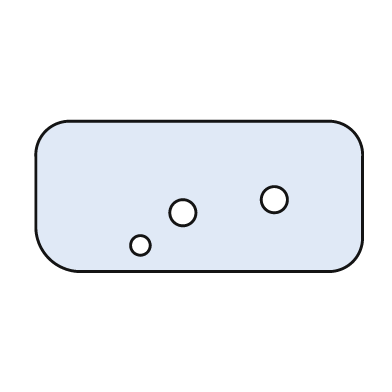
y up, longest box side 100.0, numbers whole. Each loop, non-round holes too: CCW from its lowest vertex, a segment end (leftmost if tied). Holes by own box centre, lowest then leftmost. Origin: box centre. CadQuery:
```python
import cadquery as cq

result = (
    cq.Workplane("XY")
    .moveTo(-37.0, -23.0)
    .lineTo(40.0, -23.0)
    .threePointArc((47.0, -20.0), (50.0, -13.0))
    .lineTo(50.0, 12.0)
    .threePointArc((47.0, 20.0), (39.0, 23.0))
    .lineTo(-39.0, 23.0)
    .threePointArc((-47.0, 20.0), (-50.0, 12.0))
    .lineTo(-50.0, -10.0)
    .threePointArc((-46.0, -19.0), (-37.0, -23.0))
    .close()
    .moveTo(-18.0, -15.0)
    .circle(3.0)
    .moveTo(-5.0, -5.0)
    .circle(4.0)
    .moveTo(23.0, -1.0)
    .circle(4.0)
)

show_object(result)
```